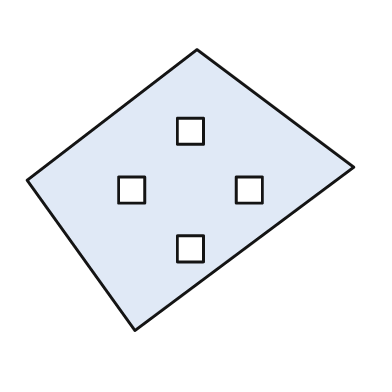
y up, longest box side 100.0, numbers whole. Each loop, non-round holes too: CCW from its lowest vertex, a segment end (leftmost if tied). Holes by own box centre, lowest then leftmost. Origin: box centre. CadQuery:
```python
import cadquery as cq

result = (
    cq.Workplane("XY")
    .moveTo(-17.0, -43.0)
    .lineTo(50.0, 7.0)
    .lineTo(2.0, 43.0)
    .lineTo(-50.0, 3.0)
    .close()
    .moveTo(-4.0, -22.0)
    .lineTo(4.0, -22.0)
    .lineTo(4.0, -14.0)
    .lineTo(-4.0, -14.0)
    .close()
    .moveTo(-22.0, -4.0)
    .lineTo(-14.0, -4.0)
    .lineTo(-14.0, 4.0)
    .lineTo(-22.0, 4.0)
    .close()
    .moveTo(14.0, -4.0)
    .lineTo(22.0, -4.0)
    .lineTo(22.0, 4.0)
    .lineTo(14.0, 4.0)
    .close()
    .moveTo(-4.0, 14.0)
    .lineTo(4.0, 14.0)
    .lineTo(4.0, 22.0)
    .lineTo(-4.0, 22.0)
    .close()
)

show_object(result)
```